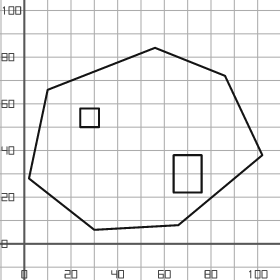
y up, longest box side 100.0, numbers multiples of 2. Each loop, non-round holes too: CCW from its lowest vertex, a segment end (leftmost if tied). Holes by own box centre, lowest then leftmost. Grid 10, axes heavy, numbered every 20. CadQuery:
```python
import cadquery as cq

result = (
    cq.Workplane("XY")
    .moveTo(30.0, 6.0)
    .lineTo(66.0, 8.0)
    .lineTo(102.0, 38.0)
    .lineTo(86.0, 72.0)
    .lineTo(56.0, 84.0)
    .lineTo(10.0, 66.0)
    .lineTo(2.0, 28.0)
    .close()
    .moveTo(64.0, 22.0)
    .lineTo(76.0, 22.0)
    .lineTo(76.0, 38.0)
    .lineTo(64.0, 38.0)
    .close()
    .moveTo(24.0, 50.0)
    .lineTo(32.0, 50.0)
    .lineTo(32.0, 58.0)
    .lineTo(24.0, 58.0)
    .close()
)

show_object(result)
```